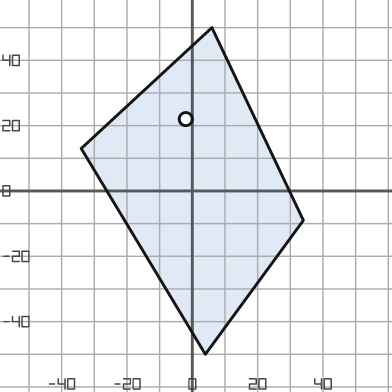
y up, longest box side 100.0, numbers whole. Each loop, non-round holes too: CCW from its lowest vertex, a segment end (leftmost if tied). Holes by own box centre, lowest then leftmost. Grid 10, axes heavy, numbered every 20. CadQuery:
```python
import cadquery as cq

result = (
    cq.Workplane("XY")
    .moveTo(4.0, -50.0)
    .lineTo(34.0, -9.0)
    .lineTo(6.0, 50.0)
    .lineTo(-34.0, 13.0)
    .close()
    .moveTo(-2.0, 22.0)
    .circle(2.0)
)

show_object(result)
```